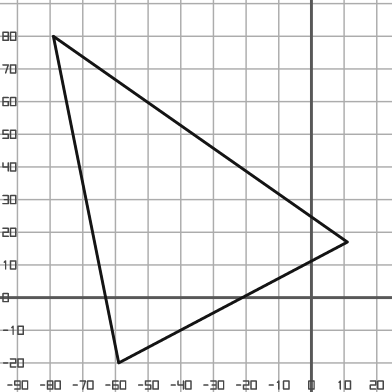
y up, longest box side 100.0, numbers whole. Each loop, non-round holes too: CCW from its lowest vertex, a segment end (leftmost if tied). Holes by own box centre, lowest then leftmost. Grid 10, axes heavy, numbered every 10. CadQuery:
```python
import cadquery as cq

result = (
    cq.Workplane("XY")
    .moveTo(-59.0, -20.0)
    .lineTo(11.0, 17.0)
    .lineTo(-79.0, 80.0)
    .close()
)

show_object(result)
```